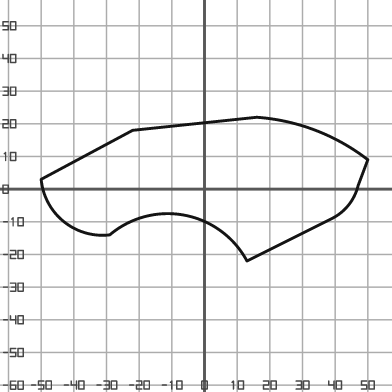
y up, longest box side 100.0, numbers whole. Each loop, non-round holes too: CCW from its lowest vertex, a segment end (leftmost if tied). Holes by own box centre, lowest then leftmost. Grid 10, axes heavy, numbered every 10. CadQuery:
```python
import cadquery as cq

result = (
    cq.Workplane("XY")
    .moveTo(13.0, -22.0)
    .lineTo(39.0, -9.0)
    .threePointArc((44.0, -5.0), (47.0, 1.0))
    .lineTo(50.0, 9.0)
    .threePointArc((34.0, 18.0), (16.0, 22.0))
    .lineTo(-22.0, 18.0)
    .lineTo(-50.0, 3.0)
    .threePointArc((-43.0, -10.0), (-29.0, -14.0))
    .threePointArc((-6.0, -8.0), (13.0, -22.0))
    .close()
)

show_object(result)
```